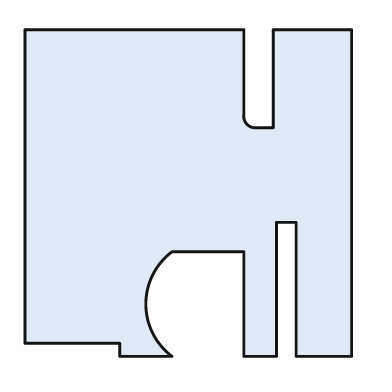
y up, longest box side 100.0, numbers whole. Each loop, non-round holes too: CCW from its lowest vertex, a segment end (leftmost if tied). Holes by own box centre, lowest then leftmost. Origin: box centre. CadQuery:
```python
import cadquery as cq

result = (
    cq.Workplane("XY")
    .moveTo(-21.0, -50.0)
    .lineTo(-5.0, -50.0)
    .threePointArc((-13.0, -34.0), (-5.0, -18.0))
    .lineTo(17.0, -18.0)
    .lineTo(17.0, -50.0)
    .lineTo(27.0, -50.0)
    .lineTo(27.0, -9.0)
    .lineTo(33.0, -9.0)
    .lineTo(33.0, -50.0)
    .lineTo(50.0, -50.0)
    .lineTo(50.0, 50.0)
    .lineTo(26.0, 50.0)
    .lineTo(26.0, 20.0)
    .lineTo(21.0, 20.0)
    .threePointArc((18.0, 21.0), (17.0, 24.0))
    .lineTo(17.0, 50.0)
    .lineTo(-50.0, 50.0)
    .lineTo(-50.0, -46.0)
    .lineTo(-21.0, -46.0)
    .close()
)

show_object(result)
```